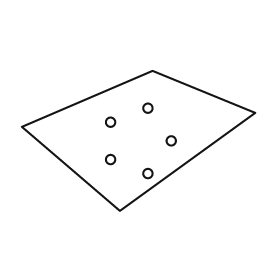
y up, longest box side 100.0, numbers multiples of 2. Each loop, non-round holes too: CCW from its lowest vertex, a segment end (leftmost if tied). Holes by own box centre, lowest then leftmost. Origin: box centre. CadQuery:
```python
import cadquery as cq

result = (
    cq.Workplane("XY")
    .moveTo(-8.0, -30.0)
    .lineTo(50.0, 12.0)
    .lineTo(6.0, 30.0)
    .lineTo(-50.0, 6.0)
    .close()
    .moveTo(4.0, -14.0)
    .circle(2.0)
    .moveTo(-12.0, -8.0)
    .circle(2.0)
    .moveTo(14.0, 0.0)
    .circle(2.0)
    .moveTo(-12.0, 8.0)
    .circle(2.0)
    .moveTo(4.0, 14.0)
    .circle(2.0)
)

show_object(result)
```